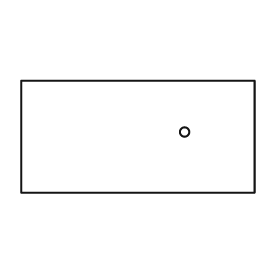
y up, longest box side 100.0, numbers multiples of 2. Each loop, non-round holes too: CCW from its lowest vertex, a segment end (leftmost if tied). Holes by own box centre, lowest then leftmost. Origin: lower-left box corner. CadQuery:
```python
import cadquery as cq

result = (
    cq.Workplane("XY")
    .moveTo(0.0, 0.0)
    .lineTo(100.0, 0.0)
    .lineTo(100.0, 48.0)
    .lineTo(0.0, 48.0)
    .close()
    .moveTo(70.0, 26.0)
    .circle(2.0)
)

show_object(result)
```